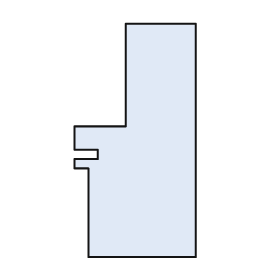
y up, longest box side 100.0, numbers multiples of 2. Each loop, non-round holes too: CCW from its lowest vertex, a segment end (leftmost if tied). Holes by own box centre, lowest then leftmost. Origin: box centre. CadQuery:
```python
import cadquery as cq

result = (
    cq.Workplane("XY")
    .moveTo(-20.0, -50.0)
    .lineTo(26.0, -50.0)
    .lineTo(26.0, 50.0)
    .lineTo(-4.0, 50.0)
    .lineTo(-4.0, 6.0)
    .lineTo(-26.0, 6.0)
    .lineTo(-26.0, -4.0)
    .lineTo(-16.0, -4.0)
    .lineTo(-16.0, -8.0)
    .lineTo(-26.0, -8.0)
    .lineTo(-26.0, -12.0)
    .lineTo(-20.0, -12.0)
    .close()
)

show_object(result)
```